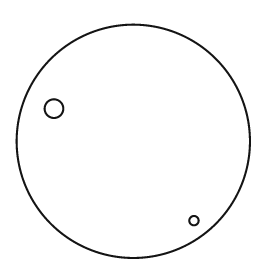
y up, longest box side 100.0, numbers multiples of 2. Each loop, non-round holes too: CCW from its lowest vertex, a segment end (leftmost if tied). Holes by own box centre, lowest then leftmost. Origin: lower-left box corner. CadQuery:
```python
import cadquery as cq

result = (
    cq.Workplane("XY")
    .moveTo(50.0, 50.0)
    .circle(50.0)
    .moveTo(76.0, 16.0)
    .circle(2.0)
    .moveTo(16.0, 64.0)
    .circle(4.0)
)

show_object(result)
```